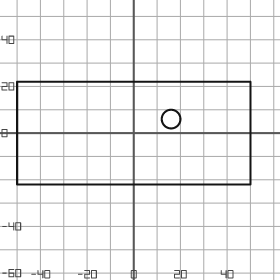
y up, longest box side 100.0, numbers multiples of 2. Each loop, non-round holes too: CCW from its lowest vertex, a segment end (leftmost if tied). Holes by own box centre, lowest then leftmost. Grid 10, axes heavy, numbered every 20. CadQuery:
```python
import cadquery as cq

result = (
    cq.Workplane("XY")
    .moveTo(-50.0, -22.0)
    .lineTo(50.0, -22.0)
    .lineTo(50.0, 22.0)
    .lineTo(-50.0, 22.0)
    .close()
    .moveTo(16.0, 6.0)
    .circle(4.0)
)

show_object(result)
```